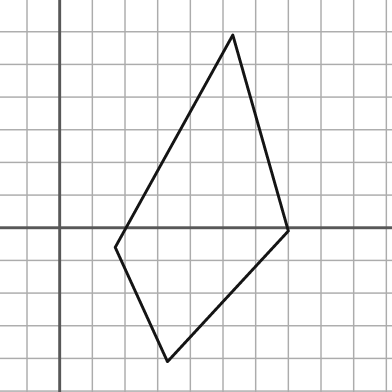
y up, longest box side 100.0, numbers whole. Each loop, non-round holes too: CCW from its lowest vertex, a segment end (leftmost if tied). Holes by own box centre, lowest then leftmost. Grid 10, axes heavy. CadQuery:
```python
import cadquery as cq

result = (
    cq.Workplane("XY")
    .moveTo(33.0, -41.0)
    .lineTo(70.0, -1.0)
    .lineTo(53.0, 59.0)
    .lineTo(17.0, -6.0)
    .close()
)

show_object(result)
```